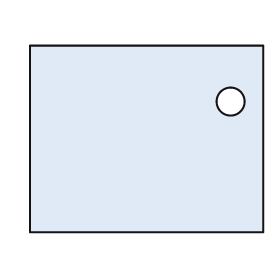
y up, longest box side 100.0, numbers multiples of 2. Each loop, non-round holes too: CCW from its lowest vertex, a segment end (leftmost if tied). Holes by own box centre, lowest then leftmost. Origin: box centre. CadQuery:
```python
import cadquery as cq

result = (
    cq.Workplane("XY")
    .moveTo(-50.0, -40.0)
    .lineTo(50.0, -40.0)
    .lineTo(50.0, 40.0)
    .lineTo(-50.0, 40.0)
    .close()
    .moveTo(36.0, 16.0)
    .circle(6.0)
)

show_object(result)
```